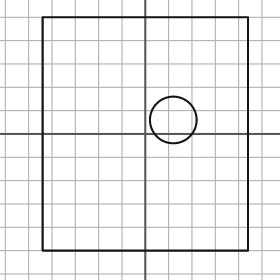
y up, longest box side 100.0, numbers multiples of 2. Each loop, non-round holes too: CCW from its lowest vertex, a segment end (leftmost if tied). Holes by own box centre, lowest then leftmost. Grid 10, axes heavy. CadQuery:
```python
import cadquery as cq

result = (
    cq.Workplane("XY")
    .moveTo(-44.0, -50.0)
    .lineTo(44.0, -50.0)
    .lineTo(44.0, 50.0)
    .lineTo(-44.0, 50.0)
    .close()
    .moveTo(12.0, 6.0)
    .circle(10.0)
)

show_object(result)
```